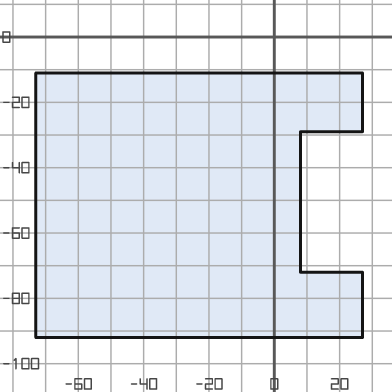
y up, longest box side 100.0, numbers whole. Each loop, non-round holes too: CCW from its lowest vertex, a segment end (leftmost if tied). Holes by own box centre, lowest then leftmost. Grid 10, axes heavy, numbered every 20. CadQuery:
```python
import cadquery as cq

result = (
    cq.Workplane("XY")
    .moveTo(-73.0, -92.0)
    .lineTo(27.0, -92.0)
    .lineTo(27.0, -72.0)
    .lineTo(8.0, -72.0)
    .lineTo(8.0, -29.0)
    .lineTo(27.0, -29.0)
    .lineTo(27.0, -11.0)
    .lineTo(-73.0, -11.0)
    .close()
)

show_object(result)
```